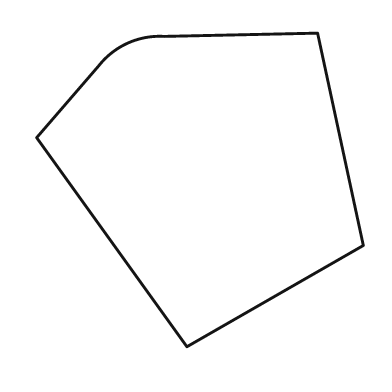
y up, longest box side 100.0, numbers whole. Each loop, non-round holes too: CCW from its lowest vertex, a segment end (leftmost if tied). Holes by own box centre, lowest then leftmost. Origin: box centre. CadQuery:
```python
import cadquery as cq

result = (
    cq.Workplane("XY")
    .moveTo(-4.0, -48.0)
    .lineTo(50.0, -17.0)
    .lineTo(36.0, 48.0)
    .lineTo(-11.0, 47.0)
    .threePointArc((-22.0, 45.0), (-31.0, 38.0))
    .lineTo(-50.0, 16.0)
    .close()
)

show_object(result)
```